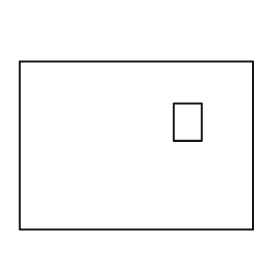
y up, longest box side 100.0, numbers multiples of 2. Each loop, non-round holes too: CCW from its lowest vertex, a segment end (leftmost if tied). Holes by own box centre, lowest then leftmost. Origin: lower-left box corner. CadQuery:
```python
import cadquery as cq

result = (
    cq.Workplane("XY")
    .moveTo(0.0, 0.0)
    .lineTo(100.0, 0.0)
    .lineTo(100.0, 72.0)
    .lineTo(0.0, 72.0)
    .close()
    .moveTo(66.0, 38.0)
    .lineTo(78.0, 38.0)
    .lineTo(78.0, 54.0)
    .lineTo(66.0, 54.0)
    .close()
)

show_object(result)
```